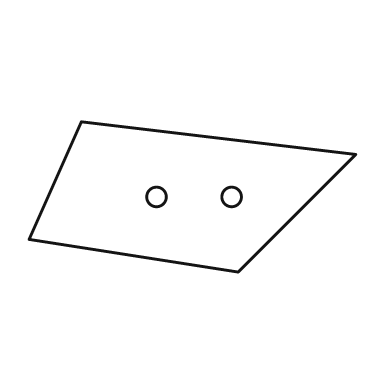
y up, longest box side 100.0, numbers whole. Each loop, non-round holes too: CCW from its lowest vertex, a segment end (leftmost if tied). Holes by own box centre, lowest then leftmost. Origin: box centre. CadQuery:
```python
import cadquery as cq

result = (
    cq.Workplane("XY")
    .moveTo(14.0, -23.0)
    .lineTo(50.0, 13.0)
    .lineTo(-34.0, 23.0)
    .lineTo(-50.0, -13.0)
    .close()
    .moveTo(-11.0, 0.0)
    .circle(3.0)
    .moveTo(12.0, 0.0)
    .circle(3.0)
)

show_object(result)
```